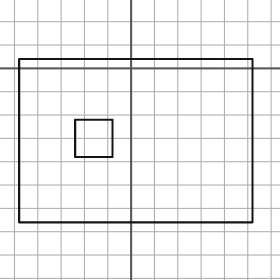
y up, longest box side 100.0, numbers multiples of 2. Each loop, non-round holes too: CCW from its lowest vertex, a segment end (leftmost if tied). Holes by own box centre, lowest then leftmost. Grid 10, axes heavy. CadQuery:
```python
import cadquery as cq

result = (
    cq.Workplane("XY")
    .moveTo(-48.0, -66.0)
    .lineTo(52.0, -66.0)
    .lineTo(52.0, 4.0)
    .lineTo(-48.0, 4.0)
    .close()
    .moveTo(-24.0, -38.0)
    .lineTo(-8.0, -38.0)
    .lineTo(-8.0, -22.0)
    .lineTo(-24.0, -22.0)
    .close()
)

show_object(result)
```